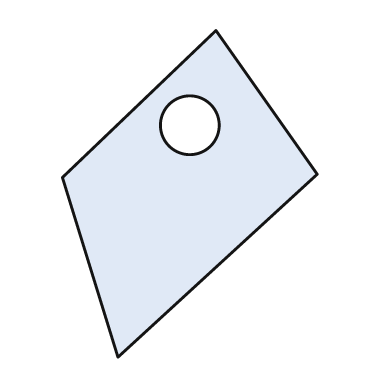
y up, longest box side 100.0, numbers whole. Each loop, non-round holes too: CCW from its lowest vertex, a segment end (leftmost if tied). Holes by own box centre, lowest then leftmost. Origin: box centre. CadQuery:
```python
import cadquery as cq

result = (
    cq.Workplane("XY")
    .moveTo(-22.0, -50.0)
    .lineTo(39.0, 6.0)
    .lineTo(8.0, 50.0)
    .lineTo(-39.0, 5.0)
    .close()
    .moveTo(0.0, 21.0)
    .circle(9.0)
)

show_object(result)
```